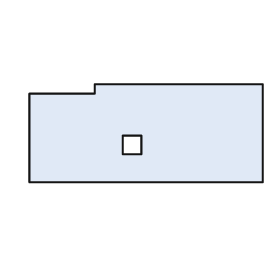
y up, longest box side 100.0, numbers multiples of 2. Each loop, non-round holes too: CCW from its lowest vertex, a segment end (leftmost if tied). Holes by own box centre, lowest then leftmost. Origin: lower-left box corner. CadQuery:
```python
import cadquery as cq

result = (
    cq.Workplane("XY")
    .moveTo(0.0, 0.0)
    .lineTo(100.0, 0.0)
    .lineTo(100.0, 42.0)
    .lineTo(28.0, 42.0)
    .lineTo(28.0, 38.0)
    .lineTo(0.0, 38.0)
    .close()
    .moveTo(40.0, 12.0)
    .lineTo(48.0, 12.0)
    .lineTo(48.0, 20.0)
    .lineTo(40.0, 20.0)
    .close()
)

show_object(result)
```